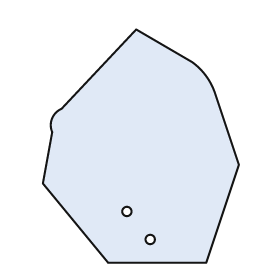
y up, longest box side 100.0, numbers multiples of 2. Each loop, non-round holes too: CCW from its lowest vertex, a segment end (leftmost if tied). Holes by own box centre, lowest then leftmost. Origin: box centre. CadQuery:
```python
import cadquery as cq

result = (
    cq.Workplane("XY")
    .moveTo(-14.0, -50.0)
    .lineTo(28.0, -50.0)
    .lineTo(42.0, -8.0)
    .lineTo(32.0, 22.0)
    .threePointArc((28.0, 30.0), (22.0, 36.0))
    .lineTo(-2.0, 50.0)
    .lineTo(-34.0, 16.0)
    .threePointArc((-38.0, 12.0), (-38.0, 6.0))
    .lineTo(-42.0, -16.0)
    .close()
    .moveTo(4.0, -40.0)
    .circle(2.0)
    .moveTo(-6.0, -28.0)
    .circle(2.0)
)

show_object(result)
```